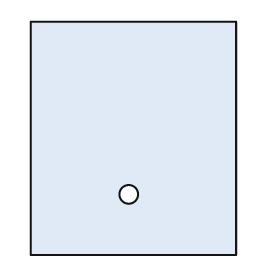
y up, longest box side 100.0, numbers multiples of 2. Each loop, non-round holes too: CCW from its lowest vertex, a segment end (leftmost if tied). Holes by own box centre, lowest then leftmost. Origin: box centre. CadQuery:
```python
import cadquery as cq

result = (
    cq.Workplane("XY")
    .moveTo(-44.0, -50.0)
    .lineTo(44.0, -50.0)
    .lineTo(44.0, 50.0)
    .lineTo(-44.0, 50.0)
    .close()
    .moveTo(-2.0, -24.0)
    .circle(4.0)
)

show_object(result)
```